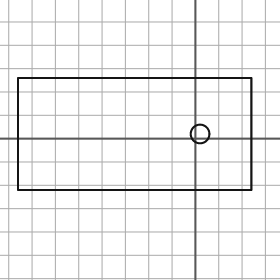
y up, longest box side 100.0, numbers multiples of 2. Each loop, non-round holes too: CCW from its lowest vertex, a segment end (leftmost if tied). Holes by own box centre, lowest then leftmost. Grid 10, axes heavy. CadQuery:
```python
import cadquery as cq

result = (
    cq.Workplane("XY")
    .moveTo(-76.0, -22.0)
    .lineTo(24.0, -22.0)
    .lineTo(24.0, 26.0)
    .lineTo(-76.0, 26.0)
    .close()
    .moveTo(2.0, 2.0)
    .circle(4.0)
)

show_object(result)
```